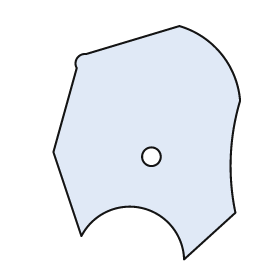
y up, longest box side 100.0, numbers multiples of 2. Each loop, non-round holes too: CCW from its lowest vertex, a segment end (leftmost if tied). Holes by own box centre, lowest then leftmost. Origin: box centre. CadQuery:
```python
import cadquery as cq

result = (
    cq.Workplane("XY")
    .moveTo(16.0, -50.0)
    .lineTo(38.0, -30.0)
    .threePointArc((36.0, -6.0), (40.0, 18.0))
    .threePointArc((32.0, 38.0), (14.0, 50.0))
    .lineTo(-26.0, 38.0)
    .threePointArc((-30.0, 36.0), (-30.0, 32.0))
    .lineTo(-40.0, -4.0)
    .lineTo(-28.0, -40.0)
    .threePointArc((-2.0, -28.0), (16.0, -50.0))
    .close()
    .moveTo(2.0, -6.0)
    .circle(4.0)
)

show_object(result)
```